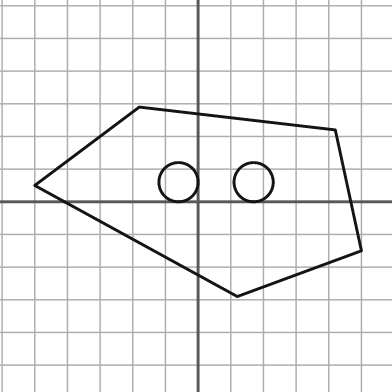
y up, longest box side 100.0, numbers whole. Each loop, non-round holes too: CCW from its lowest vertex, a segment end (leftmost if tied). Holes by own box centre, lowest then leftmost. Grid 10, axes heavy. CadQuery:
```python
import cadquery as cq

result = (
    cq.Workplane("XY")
    .moveTo(12.0, -29.0)
    .lineTo(50.0, -15.0)
    .lineTo(42.0, 22.0)
    .lineTo(-18.0, 29.0)
    .lineTo(-50.0, 5.0)
    .close()
    .moveTo(-6.0, 6.0)
    .circle(6.0)
    .moveTo(17.0, 6.0)
    .circle(6.0)
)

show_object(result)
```